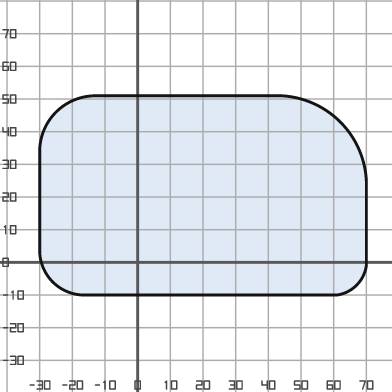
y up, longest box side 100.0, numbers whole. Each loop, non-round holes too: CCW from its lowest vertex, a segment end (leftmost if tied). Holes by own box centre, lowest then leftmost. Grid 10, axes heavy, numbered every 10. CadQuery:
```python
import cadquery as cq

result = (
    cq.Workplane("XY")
    .moveTo(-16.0, -10.0)
    .lineTo(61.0, -10.0)
    .threePointArc((67.0, -7.0), (70.0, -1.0))
    .lineTo(70.0, 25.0)
    .threePointArc((62.0, 43.0), (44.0, 51.0))
    .lineTo(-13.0, 51.0)
    .threePointArc((-25.0, 46.0), (-30.0, 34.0))
    .lineTo(-30.0, 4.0)
    .threePointArc((-26.0, -6.0), (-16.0, -10.0))
    .close()
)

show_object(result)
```